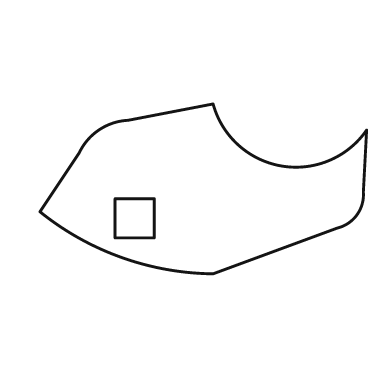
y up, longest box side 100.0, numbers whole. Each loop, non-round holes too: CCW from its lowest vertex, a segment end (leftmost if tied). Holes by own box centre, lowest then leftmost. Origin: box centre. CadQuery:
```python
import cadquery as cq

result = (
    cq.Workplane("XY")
    .moveTo(3.0, -26.0)
    .lineTo(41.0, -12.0)
    .threePointArc((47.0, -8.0), (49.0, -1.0))
    .lineTo(50.0, 18.0)
    .threePointArc((24.0, 7.0), (3.0, 26.0))
    .lineTo(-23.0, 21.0)
    .threePointArc((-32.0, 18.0), (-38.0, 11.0))
    .lineTo(-50.0, -7.0)
    .threePointArc((-25.0, -21.0), (3.0, -26.0))
    .close()
    .moveTo(-27.0, -15.0)
    .lineTo(-15.0, -15.0)
    .lineTo(-15.0, -3.0)
    .lineTo(-27.0, -3.0)
    .close()
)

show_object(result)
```